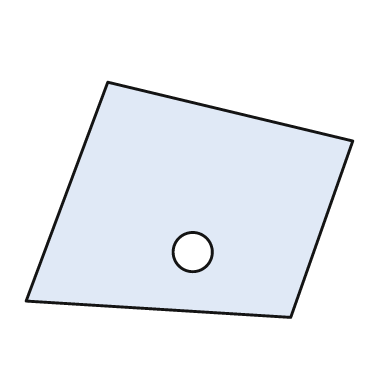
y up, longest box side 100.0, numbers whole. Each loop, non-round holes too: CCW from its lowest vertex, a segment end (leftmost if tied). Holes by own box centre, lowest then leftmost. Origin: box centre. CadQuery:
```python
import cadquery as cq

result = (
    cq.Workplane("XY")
    .moveTo(31.0, -36.0)
    .lineTo(50.0, 18.0)
    .lineTo(-25.0, 36.0)
    .lineTo(-50.0, -31.0)
    .close()
    .moveTo(1.0, -16.0)
    .circle(6.0)
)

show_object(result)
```